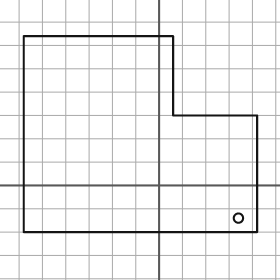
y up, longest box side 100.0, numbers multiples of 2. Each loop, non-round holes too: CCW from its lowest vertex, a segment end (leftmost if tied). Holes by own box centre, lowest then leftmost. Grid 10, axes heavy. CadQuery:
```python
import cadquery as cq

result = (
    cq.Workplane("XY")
    .moveTo(-58.0, -20.0)
    .lineTo(42.0, -20.0)
    .lineTo(42.0, 30.0)
    .lineTo(6.0, 30.0)
    .lineTo(6.0, 64.0)
    .lineTo(-58.0, 64.0)
    .close()
    .moveTo(34.0, -14.0)
    .circle(2.0)
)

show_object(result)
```